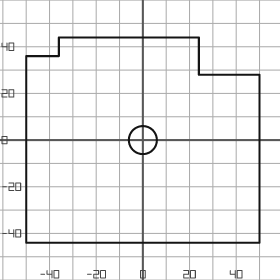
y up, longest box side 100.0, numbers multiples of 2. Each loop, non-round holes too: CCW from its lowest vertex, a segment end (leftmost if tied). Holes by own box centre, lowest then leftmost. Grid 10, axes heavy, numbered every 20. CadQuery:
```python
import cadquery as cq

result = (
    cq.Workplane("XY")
    .moveTo(-50.0, -44.0)
    .lineTo(50.0, -44.0)
    .lineTo(50.0, 28.0)
    .lineTo(24.0, 28.0)
    .lineTo(24.0, 44.0)
    .lineTo(-36.0, 44.0)
    .lineTo(-36.0, 36.0)
    .lineTo(-50.0, 36.0)
    .close()
    .moveTo(0.0, 0.0)
    .circle(6.0)
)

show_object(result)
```